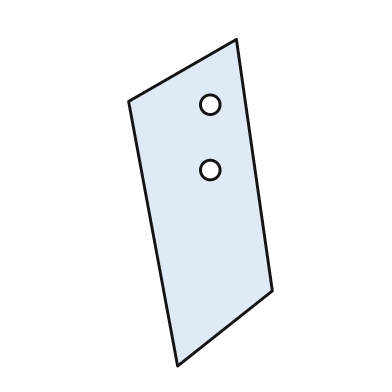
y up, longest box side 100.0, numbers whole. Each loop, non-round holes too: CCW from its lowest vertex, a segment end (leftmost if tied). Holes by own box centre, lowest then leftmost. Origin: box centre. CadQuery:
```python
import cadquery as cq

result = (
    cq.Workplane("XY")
    .moveTo(-7.0, -50.0)
    .lineTo(22.0, -27.0)
    .lineTo(11.0, 50.0)
    .lineTo(-22.0, 31.0)
    .close()
    .moveTo(3.0, 10.0)
    .circle(3.0)
    .moveTo(3.0, 30.0)
    .circle(3.0)
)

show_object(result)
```